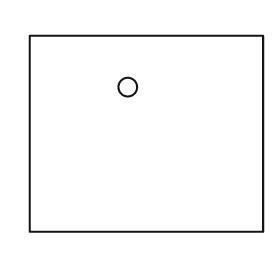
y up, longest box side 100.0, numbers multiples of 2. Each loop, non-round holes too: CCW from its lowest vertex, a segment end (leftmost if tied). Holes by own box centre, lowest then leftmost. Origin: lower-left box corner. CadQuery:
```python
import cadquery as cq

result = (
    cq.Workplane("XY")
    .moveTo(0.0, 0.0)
    .lineTo(100.0, 0.0)
    .lineTo(100.0, 84.0)
    .lineTo(0.0, 84.0)
    .close()
    .moveTo(42.0, 62.0)
    .circle(4.0)
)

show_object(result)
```